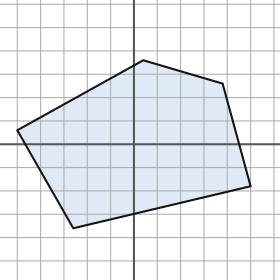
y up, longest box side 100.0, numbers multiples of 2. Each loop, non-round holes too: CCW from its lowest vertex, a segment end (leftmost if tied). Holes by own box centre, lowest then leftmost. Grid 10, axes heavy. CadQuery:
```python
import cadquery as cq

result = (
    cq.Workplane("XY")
    .moveTo(-26.0, -36.0)
    .lineTo(50.0, -18.0)
    .lineTo(38.0, 26.0)
    .lineTo(4.0, 36.0)
    .lineTo(-50.0, 6.0)
    .close()
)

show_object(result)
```